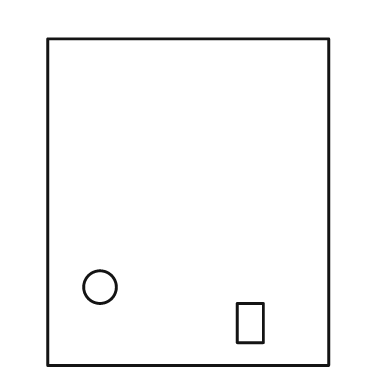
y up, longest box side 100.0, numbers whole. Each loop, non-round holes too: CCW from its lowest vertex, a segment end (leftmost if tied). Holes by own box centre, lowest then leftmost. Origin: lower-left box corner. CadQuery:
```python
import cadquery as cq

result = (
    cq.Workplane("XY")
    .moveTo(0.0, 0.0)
    .lineTo(86.0, 0.0)
    .lineTo(86.0, 100.0)
    .lineTo(0.0, 100.0)
    .close()
    .moveTo(58.0, 7.0)
    .lineTo(66.0, 7.0)
    .lineTo(66.0, 19.0)
    .lineTo(58.0, 19.0)
    .close()
    .moveTo(16.0, 24.0)
    .circle(5.0)
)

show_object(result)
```